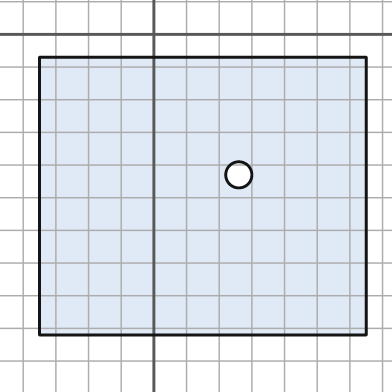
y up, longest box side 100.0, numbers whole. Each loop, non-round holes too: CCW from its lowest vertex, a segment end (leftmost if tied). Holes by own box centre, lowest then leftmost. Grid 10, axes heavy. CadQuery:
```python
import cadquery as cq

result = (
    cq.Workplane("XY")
    .moveTo(-35.0, -92.0)
    .lineTo(65.0, -92.0)
    .lineTo(65.0, -7.0)
    .lineTo(-35.0, -7.0)
    .close()
    .moveTo(26.0, -43.0)
    .circle(4.0)
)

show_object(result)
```